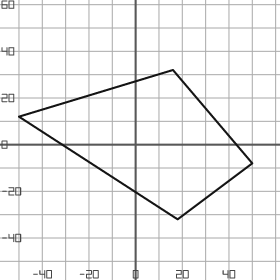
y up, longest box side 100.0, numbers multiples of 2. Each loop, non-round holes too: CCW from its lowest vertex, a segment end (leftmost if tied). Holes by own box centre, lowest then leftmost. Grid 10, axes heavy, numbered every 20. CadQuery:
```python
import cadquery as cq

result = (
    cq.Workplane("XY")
    .moveTo(18.0, -32.0)
    .lineTo(50.0, -8.0)
    .lineTo(16.0, 32.0)
    .lineTo(-50.0, 12.0)
    .close()
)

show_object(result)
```